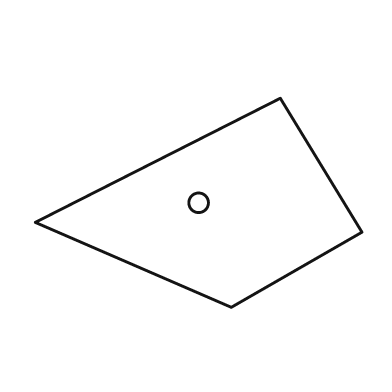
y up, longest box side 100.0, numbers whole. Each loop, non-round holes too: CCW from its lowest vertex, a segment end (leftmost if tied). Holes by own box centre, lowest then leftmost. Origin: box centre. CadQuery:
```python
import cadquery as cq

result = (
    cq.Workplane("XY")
    .moveTo(10.0, -32.0)
    .lineTo(50.0, -9.0)
    .lineTo(25.0, 32.0)
    .lineTo(-50.0, -6.0)
    .close()
    .moveTo(0.0, 0.0)
    .circle(3.0)
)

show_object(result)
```